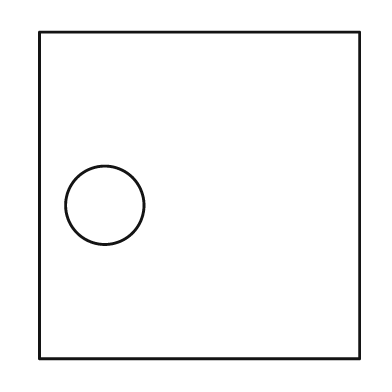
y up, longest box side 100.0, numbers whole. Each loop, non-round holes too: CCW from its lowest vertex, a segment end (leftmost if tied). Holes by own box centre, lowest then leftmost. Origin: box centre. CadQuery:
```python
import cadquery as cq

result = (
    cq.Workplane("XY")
    .moveTo(-49.0, -50.0)
    .lineTo(49.0, -50.0)
    .lineTo(49.0, 50.0)
    .lineTo(-49.0, 50.0)
    .close()
    .moveTo(-29.0, -3.0)
    .circle(12.0)
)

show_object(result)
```